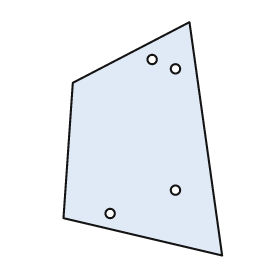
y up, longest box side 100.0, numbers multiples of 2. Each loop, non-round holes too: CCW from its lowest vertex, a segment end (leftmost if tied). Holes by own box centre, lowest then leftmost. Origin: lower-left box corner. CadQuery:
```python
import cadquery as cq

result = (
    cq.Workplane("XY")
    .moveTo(68.0, 0.0)
    .lineTo(54.0, 100.0)
    .lineTo(4.0, 74.0)
    .lineTo(0.0, 16.0)
    .close()
    .moveTo(20.0, 18.0)
    .circle(2.0)
    .moveTo(48.0, 28.0)
    .circle(2.0)
    .moveTo(48.0, 80.0)
    .circle(2.0)
    .moveTo(38.0, 84.0)
    .circle(2.0)
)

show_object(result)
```